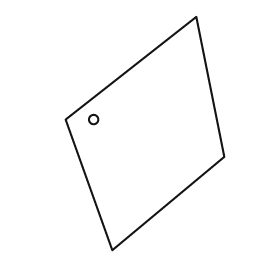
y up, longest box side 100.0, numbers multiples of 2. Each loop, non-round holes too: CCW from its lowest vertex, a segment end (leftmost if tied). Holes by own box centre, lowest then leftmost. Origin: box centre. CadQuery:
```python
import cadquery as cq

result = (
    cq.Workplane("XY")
    .moveTo(-14.0, -50.0)
    .lineTo(34.0, -10.0)
    .lineTo(22.0, 50.0)
    .lineTo(-34.0, 6.0)
    .close()
    .moveTo(-22.0, 6.0)
    .circle(2.0)
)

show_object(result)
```